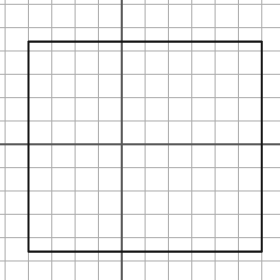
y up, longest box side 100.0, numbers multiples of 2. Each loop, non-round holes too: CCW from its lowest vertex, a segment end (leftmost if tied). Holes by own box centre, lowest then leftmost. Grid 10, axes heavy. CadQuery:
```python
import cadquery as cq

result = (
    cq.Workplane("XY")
    .moveTo(-40.0, -46.0)
    .lineTo(60.0, -46.0)
    .lineTo(60.0, 44.0)
    .lineTo(-40.0, 44.0)
    .close()
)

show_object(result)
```